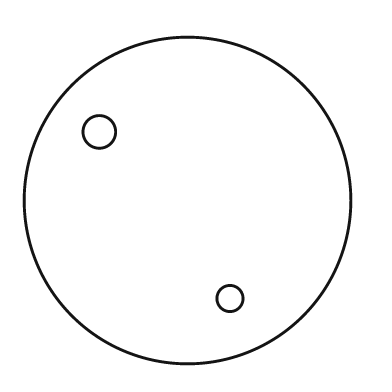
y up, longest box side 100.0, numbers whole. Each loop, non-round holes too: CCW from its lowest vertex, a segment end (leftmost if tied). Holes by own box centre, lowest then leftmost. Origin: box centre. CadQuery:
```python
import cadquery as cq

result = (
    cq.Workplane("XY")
    .moveTo(0.0, 0.0)
    .circle(50.0)
    .moveTo(13.0, -30.0)
    .circle(4.0)
    .moveTo(-27.0, 21.0)
    .circle(5.0)
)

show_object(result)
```